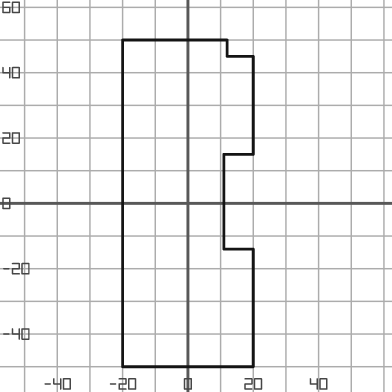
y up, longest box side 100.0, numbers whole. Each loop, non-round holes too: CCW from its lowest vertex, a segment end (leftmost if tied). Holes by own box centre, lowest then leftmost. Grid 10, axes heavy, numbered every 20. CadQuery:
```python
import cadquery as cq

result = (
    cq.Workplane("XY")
    .moveTo(-20.0, -50.0)
    .lineTo(20.0, -50.0)
    .lineTo(20.0, -14.0)
    .lineTo(11.0, -14.0)
    .lineTo(11.0, 15.0)
    .lineTo(20.0, 15.0)
    .lineTo(20.0, 45.0)
    .lineTo(12.0, 45.0)
    .lineTo(12.0, 50.0)
    .lineTo(-20.0, 50.0)
    .close()
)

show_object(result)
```